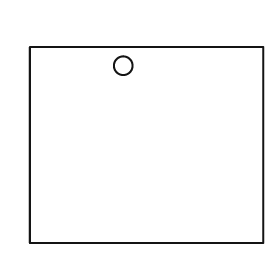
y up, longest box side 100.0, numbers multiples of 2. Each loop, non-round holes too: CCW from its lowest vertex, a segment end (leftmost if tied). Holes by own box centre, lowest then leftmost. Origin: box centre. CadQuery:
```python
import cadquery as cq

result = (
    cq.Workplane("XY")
    .moveTo(-50.0, -42.0)
    .lineTo(50.0, -42.0)
    .lineTo(50.0, 42.0)
    .lineTo(-50.0, 42.0)
    .close()
    .moveTo(-10.0, 34.0)
    .circle(4.0)
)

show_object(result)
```